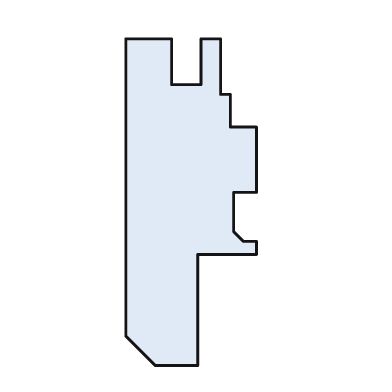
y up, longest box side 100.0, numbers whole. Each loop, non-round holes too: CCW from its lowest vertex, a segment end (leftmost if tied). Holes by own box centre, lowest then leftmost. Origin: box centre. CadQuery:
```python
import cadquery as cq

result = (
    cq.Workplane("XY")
    .moveTo(-11.0, -50.0)
    .lineTo(2.0, -50.0)
    .lineTo(2.0, -16.0)
    .lineTo(20.0, -16.0)
    .lineTo(20.0, -12.0)
    .lineTo(16.0, -12.0)
    .lineTo(13.0, -9.0)
    .lineTo(13.0, 3.0)
    .lineTo(20.0, 3.0)
    .lineTo(20.0, 23.0)
    .lineTo(12.0, 23.0)
    .lineTo(12.0, 33.0)
    .lineTo(9.0, 33.0)
    .lineTo(9.0, 50.0)
    .lineTo(3.0, 50.0)
    .lineTo(3.0, 36.0)
    .lineTo(-6.0, 36.0)
    .lineTo(-6.0, 50.0)
    .lineTo(-20.0, 50.0)
    .lineTo(-20.0, -41.0)
    .close()
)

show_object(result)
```